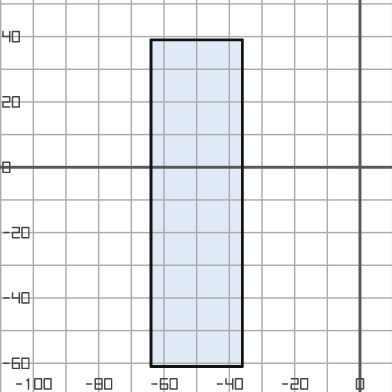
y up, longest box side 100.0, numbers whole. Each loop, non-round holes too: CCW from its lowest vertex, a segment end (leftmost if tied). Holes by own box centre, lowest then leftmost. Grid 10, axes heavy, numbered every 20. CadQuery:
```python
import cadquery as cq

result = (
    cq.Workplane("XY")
    .moveTo(-64.0, -61.0)
    .lineTo(-36.0, -61.0)
    .lineTo(-36.0, 39.0)
    .lineTo(-64.0, 39.0)
    .close()
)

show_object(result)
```